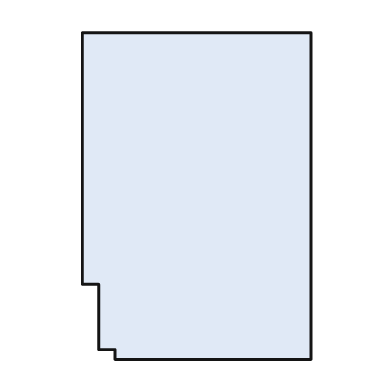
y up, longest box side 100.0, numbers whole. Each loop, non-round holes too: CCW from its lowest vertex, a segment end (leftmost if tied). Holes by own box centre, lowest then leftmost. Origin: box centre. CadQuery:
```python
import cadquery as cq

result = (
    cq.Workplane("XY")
    .moveTo(-25.0, -50.0)
    .lineTo(35.0, -50.0)
    .lineTo(35.0, 50.0)
    .lineTo(-35.0, 50.0)
    .lineTo(-35.0, -27.0)
    .lineTo(-30.0, -27.0)
    .lineTo(-30.0, -47.0)
    .lineTo(-25.0, -47.0)
    .close()
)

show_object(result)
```